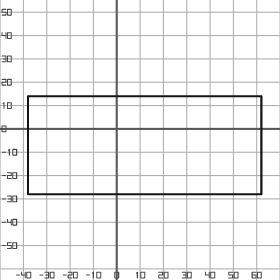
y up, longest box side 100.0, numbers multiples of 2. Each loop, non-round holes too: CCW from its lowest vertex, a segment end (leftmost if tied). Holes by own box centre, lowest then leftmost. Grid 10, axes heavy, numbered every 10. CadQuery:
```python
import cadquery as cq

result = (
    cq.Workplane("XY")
    .moveTo(-38.0, -28.0)
    .lineTo(62.0, -28.0)
    .lineTo(62.0, 14.0)
    .lineTo(-38.0, 14.0)
    .close()
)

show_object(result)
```